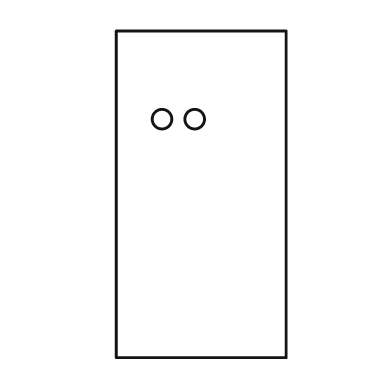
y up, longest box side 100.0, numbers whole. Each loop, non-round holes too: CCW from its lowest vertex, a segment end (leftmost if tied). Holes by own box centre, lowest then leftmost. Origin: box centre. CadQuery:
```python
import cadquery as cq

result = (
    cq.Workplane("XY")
    .moveTo(-26.0, -50.0)
    .lineTo(26.0, -50.0)
    .lineTo(26.0, 50.0)
    .lineTo(-26.0, 50.0)
    .close()
    .moveTo(-12.0, 23.0)
    .circle(3.0)
    .moveTo(-2.0, 23.0)
    .circle(3.0)
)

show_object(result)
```